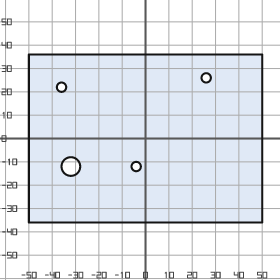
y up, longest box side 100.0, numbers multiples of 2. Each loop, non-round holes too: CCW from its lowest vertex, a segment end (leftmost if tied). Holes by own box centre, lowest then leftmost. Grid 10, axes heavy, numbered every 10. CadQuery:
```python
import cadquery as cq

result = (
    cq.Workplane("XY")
    .moveTo(-50.0, -36.0)
    .lineTo(50.0, -36.0)
    .lineTo(50.0, 36.0)
    .lineTo(-50.0, 36.0)
    .close()
    .moveTo(-32.0, -12.0)
    .circle(4.0)
    .moveTo(-4.0, -12.0)
    .circle(2.0)
    .moveTo(-36.0, 22.0)
    .circle(2.0)
    .moveTo(26.0, 26.0)
    .circle(2.0)
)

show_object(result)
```